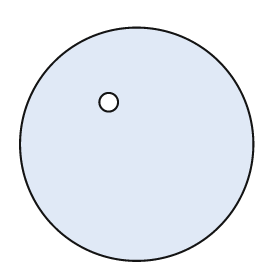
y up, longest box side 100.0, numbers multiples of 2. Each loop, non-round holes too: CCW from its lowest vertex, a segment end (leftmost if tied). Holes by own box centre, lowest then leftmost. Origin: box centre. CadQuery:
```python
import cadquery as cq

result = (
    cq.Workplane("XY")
    .moveTo(0.0, 0.0)
    .circle(50.0)
    .moveTo(-12.0, 18.0)
    .circle(4.0)
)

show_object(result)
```